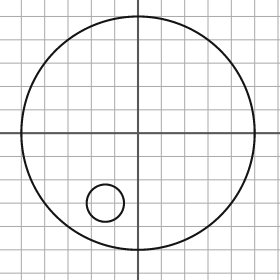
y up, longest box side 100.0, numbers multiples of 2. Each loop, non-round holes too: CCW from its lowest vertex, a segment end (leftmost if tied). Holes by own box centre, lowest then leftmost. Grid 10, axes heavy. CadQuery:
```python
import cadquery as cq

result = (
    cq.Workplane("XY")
    .moveTo(0.0, 0.0)
    .circle(50.0)
    .moveTo(-14.0, -30.0)
    .circle(8.0)
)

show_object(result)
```